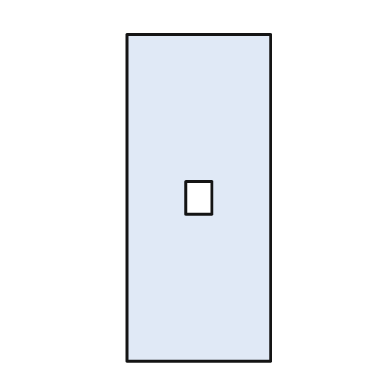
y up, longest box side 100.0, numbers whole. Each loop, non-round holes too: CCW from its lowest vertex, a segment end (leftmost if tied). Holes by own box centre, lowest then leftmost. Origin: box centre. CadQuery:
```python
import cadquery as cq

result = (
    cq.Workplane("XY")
    .moveTo(-22.0, -50.0)
    .lineTo(22.0, -50.0)
    .lineTo(22.0, 50.0)
    .lineTo(-22.0, 50.0)
    .close()
    .moveTo(-4.0, -5.0)
    .lineTo(4.0, -5.0)
    .lineTo(4.0, 5.0)
    .lineTo(-4.0, 5.0)
    .close()
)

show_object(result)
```